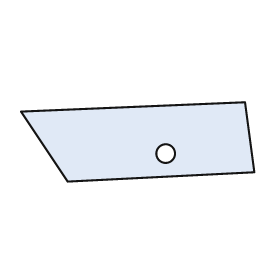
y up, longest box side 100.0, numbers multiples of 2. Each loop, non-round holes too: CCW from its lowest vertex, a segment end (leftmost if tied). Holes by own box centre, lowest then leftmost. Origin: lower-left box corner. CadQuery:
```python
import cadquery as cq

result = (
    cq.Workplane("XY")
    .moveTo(20.0, 0.0)
    .lineTo(100.0, 4.0)
    .lineTo(96.0, 34.0)
    .lineTo(0.0, 30.0)
    .close()
    .moveTo(62.0, 12.0)
    .circle(4.0)
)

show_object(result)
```